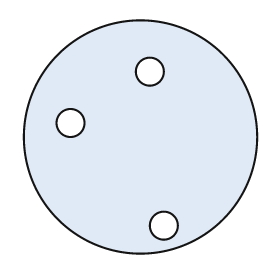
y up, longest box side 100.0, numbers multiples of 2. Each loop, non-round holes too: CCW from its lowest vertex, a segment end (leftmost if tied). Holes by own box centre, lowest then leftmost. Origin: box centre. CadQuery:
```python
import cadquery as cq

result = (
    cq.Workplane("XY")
    .moveTo(0.0, 0.0)
    .circle(50.0)
    .moveTo(10.0, -38.0)
    .circle(6.0)
    .moveTo(-30.0, 6.0)
    .circle(6.0)
    .moveTo(4.0, 28.0)
    .circle(6.0)
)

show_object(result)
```